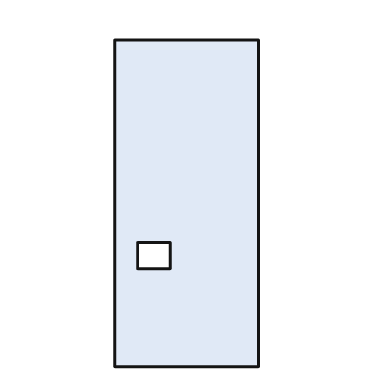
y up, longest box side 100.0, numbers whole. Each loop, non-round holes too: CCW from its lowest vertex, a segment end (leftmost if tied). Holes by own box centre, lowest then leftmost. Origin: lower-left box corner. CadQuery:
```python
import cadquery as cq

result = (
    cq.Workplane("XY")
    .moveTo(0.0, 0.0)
    .lineTo(44.0, 0.0)
    .lineTo(44.0, 100.0)
    .lineTo(0.0, 100.0)
    .close()
    .moveTo(7.0, 30.0)
    .lineTo(17.0, 30.0)
    .lineTo(17.0, 38.0)
    .lineTo(7.0, 38.0)
    .close()
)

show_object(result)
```